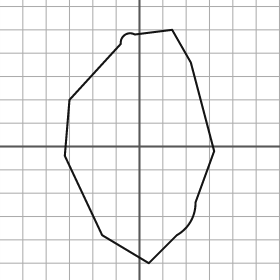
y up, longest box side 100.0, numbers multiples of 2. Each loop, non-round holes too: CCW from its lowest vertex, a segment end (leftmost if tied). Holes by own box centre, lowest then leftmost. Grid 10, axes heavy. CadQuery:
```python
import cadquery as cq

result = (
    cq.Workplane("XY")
    .moveTo(4.0, -50.0)
    .lineTo(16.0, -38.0)
    .threePointArc((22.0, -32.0), (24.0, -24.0))
    .lineTo(32.0, -2.0)
    .lineTo(22.0, 36.0)
    .lineTo(14.0, 50.0)
    .lineTo(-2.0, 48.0)
    .threePointArc((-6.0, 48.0), (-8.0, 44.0))
    .lineTo(-30.0, 20.0)
    .lineTo(-32.0, -4.0)
    .lineTo(-16.0, -38.0)
    .close()
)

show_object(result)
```